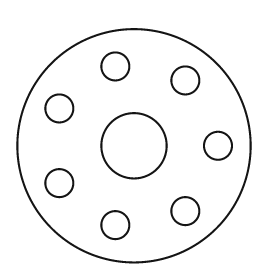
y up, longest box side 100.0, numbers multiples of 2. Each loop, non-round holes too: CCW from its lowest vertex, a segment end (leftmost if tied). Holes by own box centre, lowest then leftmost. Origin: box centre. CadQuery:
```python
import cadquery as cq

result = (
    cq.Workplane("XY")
    .moveTo(0.0, 0.0)
    .circle(50.0)
    .moveTo(-8.0, -34.0)
    .circle(6.0)
    .moveTo(22.0, -28.0)
    .circle(6.0)
    .moveTo(-32.0, -16.0)
    .circle(6.0)
    .moveTo(0.0, 0.0)
    .circle(14.0)
    .moveTo(36.0, 0.0)
    .circle(6.0)
    .moveTo(-32.0, 16.0)
    .circle(6.0)
    .moveTo(22.0, 28.0)
    .circle(6.0)
    .moveTo(-8.0, 34.0)
    .circle(6.0)
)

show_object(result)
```